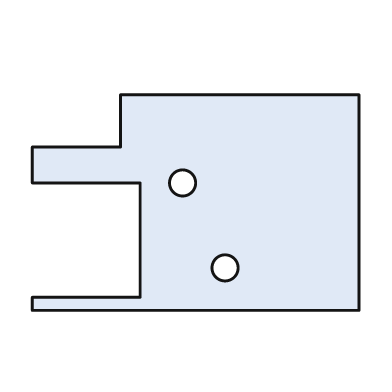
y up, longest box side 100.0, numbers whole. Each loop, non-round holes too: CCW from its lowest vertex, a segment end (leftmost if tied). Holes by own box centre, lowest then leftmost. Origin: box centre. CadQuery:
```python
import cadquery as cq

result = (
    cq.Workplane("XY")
    .moveTo(-50.0, -33.0)
    .lineTo(50.0, -33.0)
    .lineTo(50.0, 33.0)
    .lineTo(-23.0, 33.0)
    .lineTo(-23.0, 17.0)
    .lineTo(-50.0, 17.0)
    .lineTo(-50.0, 6.0)
    .lineTo(-17.0, 6.0)
    .lineTo(-17.0, -29.0)
    .lineTo(-50.0, -29.0)
    .close()
    .moveTo(9.0, -20.0)
    .circle(4.0)
    .moveTo(-4.0, 6.0)
    .circle(4.0)
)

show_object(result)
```